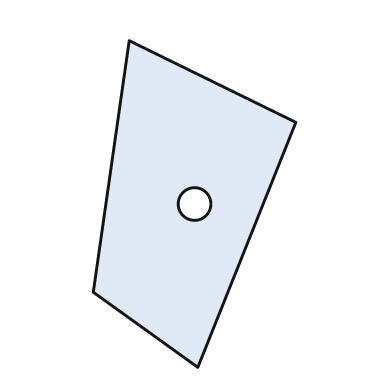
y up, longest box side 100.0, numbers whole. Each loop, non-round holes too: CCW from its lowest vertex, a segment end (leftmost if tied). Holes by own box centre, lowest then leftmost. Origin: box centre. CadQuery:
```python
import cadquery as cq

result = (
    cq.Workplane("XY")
    .moveTo(1.0, -50.0)
    .lineTo(31.0, 25.0)
    .lineTo(-20.0, 50.0)
    .lineTo(-31.0, -27.0)
    .close()
    .moveTo(0.0, 0.0)
    .circle(5.0)
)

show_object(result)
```